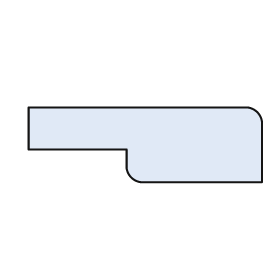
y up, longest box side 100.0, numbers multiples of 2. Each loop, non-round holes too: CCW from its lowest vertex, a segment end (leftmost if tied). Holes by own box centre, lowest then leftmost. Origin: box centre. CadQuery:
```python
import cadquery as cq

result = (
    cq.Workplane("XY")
    .moveTo(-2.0, -16.0)
    .lineTo(50.0, -16.0)
    .lineTo(50.0, 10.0)
    .threePointArc((48.0, 14.0), (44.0, 16.0))
    .lineTo(-50.0, 16.0)
    .lineTo(-50.0, -2.0)
    .lineTo(-8.0, -2.0)
    .lineTo(-8.0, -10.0)
    .threePointArc((-6.0, -14.0), (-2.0, -16.0))
    .close()
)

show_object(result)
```